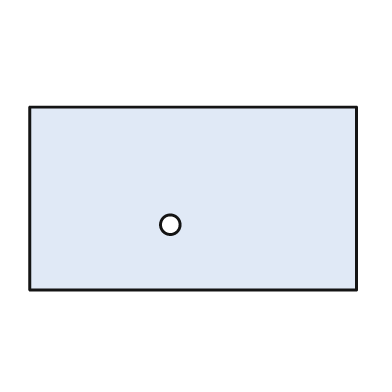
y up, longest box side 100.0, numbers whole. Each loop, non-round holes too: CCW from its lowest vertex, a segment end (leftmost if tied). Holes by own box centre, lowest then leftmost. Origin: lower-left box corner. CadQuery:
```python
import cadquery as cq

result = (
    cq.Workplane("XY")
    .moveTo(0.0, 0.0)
    .lineTo(100.0, 0.0)
    .lineTo(100.0, 56.0)
    .lineTo(0.0, 56.0)
    .close()
    .moveTo(43.0, 20.0)
    .circle(3.0)
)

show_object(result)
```